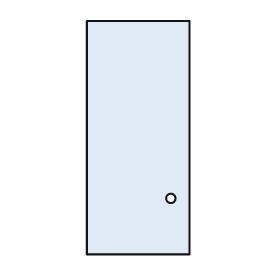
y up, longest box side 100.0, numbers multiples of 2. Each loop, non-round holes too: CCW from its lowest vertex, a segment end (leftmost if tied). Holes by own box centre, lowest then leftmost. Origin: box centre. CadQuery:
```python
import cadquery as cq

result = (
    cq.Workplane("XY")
    .moveTo(-22.0, -50.0)
    .lineTo(22.0, -50.0)
    .lineTo(22.0, 50.0)
    .lineTo(-22.0, 50.0)
    .close()
    .moveTo(14.0, -26.0)
    .circle(2.0)
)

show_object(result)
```